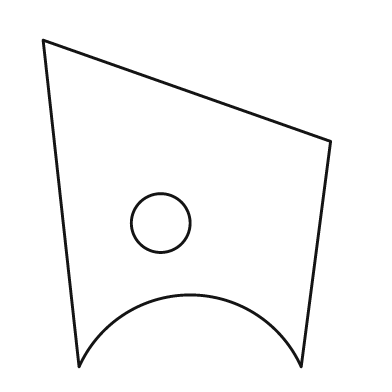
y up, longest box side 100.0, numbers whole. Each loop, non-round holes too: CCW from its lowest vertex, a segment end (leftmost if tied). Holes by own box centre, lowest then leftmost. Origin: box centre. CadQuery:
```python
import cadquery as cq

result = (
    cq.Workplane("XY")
    .moveTo(-33.0, -50.0)
    .threePointArc((1.0, -28.0), (35.0, -50.0))
    .lineTo(44.0, 19.0)
    .lineTo(-44.0, 50.0)
    .close()
    .moveTo(-8.0, -6.0)
    .circle(9.0)
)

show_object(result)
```